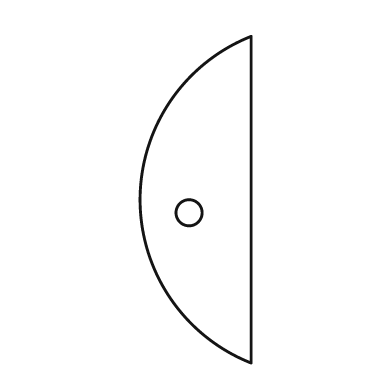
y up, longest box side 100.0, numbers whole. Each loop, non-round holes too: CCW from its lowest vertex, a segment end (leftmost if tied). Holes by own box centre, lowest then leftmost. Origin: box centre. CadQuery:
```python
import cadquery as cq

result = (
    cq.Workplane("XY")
    .moveTo(17.0, -50.0)
    .lineTo(17.0, 50.0)
    .threePointArc((-17.0, 0.0), (17.0, -50.0))
    .close()
    .moveTo(-2.0, -4.0)
    .circle(4.0)
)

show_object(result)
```